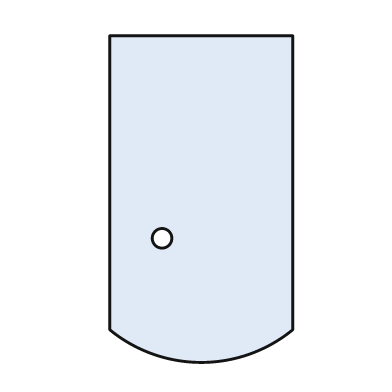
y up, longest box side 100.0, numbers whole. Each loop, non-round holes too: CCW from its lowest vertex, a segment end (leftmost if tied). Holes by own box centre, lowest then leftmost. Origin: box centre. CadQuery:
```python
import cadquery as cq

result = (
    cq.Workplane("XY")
    .moveTo(-28.0, -40.0)
    .threePointArc((0.0, -50.0), (28.0, -40.0))
    .lineTo(28.0, 50.0)
    .lineTo(-28.0, 50.0)
    .close()
    .moveTo(-12.0, -12.0)
    .circle(3.0)
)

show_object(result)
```